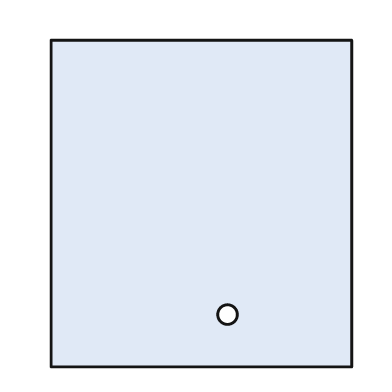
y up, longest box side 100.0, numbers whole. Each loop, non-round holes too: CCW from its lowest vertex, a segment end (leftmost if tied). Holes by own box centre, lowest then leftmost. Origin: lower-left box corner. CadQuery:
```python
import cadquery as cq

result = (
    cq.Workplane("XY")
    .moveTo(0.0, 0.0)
    .lineTo(92.0, 0.0)
    .lineTo(92.0, 100.0)
    .lineTo(0.0, 100.0)
    .close()
    .moveTo(54.0, 16.0)
    .circle(3.0)
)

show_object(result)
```